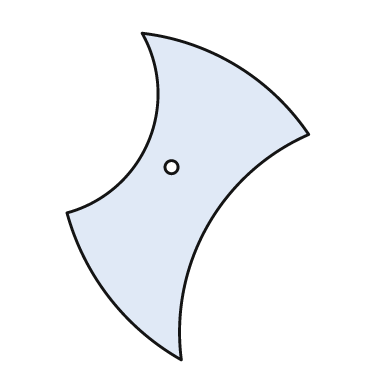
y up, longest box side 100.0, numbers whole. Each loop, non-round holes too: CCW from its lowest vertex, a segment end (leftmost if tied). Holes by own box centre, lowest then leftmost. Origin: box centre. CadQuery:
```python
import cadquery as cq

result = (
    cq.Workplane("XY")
    .moveTo(-2.0, -50.0)
    .threePointArc((6.0, -9.0), (37.0, 19.0))
    .threePointArc((15.0, 40.0), (-14.0, 50.0))
    .threePointArc((-12.0, 17.0), (-37.0, -5.0))
    .threePointArc((-24.0, -31.0), (-2.0, -50.0))
    .close()
    .moveTo(-5.0, 9.0)
    .circle(2.0)
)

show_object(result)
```